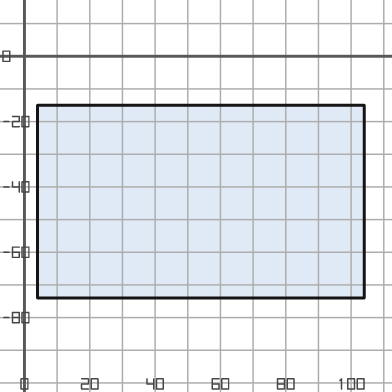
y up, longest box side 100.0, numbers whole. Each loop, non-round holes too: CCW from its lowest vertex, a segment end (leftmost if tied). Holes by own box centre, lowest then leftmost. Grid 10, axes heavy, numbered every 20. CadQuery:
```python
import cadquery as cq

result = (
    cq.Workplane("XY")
    .moveTo(4.0, -74.0)
    .lineTo(104.0, -74.0)
    .lineTo(104.0, -15.0)
    .lineTo(4.0, -15.0)
    .close()
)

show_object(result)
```